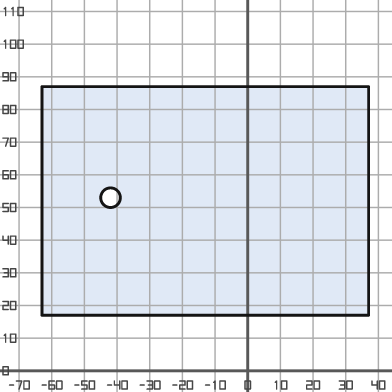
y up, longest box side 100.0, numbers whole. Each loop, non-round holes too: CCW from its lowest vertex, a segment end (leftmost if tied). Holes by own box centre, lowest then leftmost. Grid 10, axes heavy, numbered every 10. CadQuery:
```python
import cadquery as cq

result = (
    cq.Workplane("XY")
    .moveTo(-63.0, 17.0)
    .lineTo(37.0, 17.0)
    .lineTo(37.0, 87.0)
    .lineTo(-63.0, 87.0)
    .close()
    .moveTo(-42.0, 53.0)
    .circle(3.0)
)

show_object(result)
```